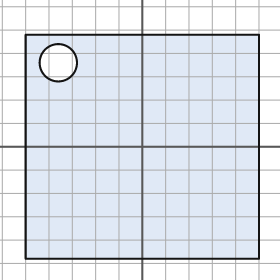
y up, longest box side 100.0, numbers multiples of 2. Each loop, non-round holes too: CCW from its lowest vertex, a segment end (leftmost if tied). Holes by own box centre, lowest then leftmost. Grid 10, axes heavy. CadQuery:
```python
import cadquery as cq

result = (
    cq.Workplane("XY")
    .moveTo(-50.0, -48.0)
    .lineTo(50.0, -48.0)
    .lineTo(50.0, 48.0)
    .lineTo(-50.0, 48.0)
    .close()
    .moveTo(-36.0, 36.0)
    .circle(8.0)
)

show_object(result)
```